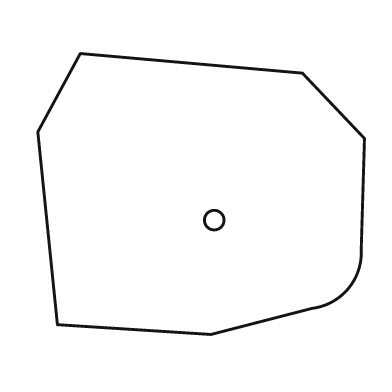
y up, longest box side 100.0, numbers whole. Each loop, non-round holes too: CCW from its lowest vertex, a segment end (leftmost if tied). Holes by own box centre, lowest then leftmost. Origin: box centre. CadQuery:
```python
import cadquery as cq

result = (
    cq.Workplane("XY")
    .moveTo(3.0, -43.0)
    .lineTo(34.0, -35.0)
    .threePointArc((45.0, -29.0), (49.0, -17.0))
    .lineTo(50.0, 17.0)
    .lineTo(31.0, 37.0)
    .lineTo(-37.0, 43.0)
    .lineTo(-50.0, 19.0)
    .lineTo(-44.0, -40.0)
    .close()
    .moveTo(4.0, -8.0)
    .circle(3.0)
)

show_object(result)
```